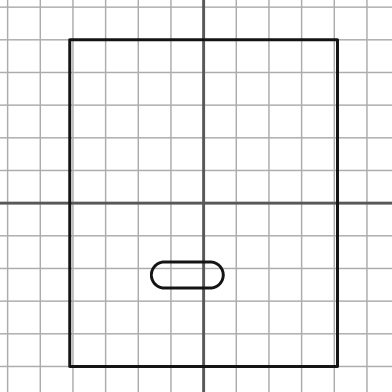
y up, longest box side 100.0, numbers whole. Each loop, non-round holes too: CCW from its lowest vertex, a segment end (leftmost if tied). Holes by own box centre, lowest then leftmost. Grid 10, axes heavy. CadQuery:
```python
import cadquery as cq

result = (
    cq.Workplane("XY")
    .moveTo(-41.0, -50.0)
    .lineTo(41.0, -50.0)
    .lineTo(41.0, 50.0)
    .lineTo(-41.0, 50.0)
    .close()
    .moveTo(-12.0, -26.0)
    .lineTo(2.0, -26.0)
    .threePointArc((6.0, -22.0), (2.0, -18.0))
    .lineTo(-12.0, -18.0)
    .threePointArc((-16.0, -22.0), (-12.0, -26.0))
    .close()
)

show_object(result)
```